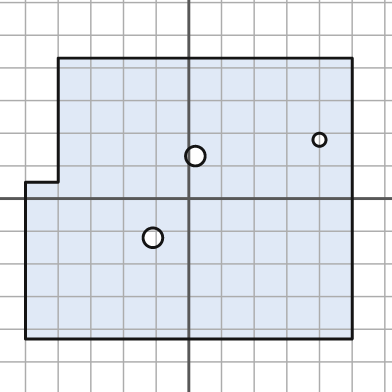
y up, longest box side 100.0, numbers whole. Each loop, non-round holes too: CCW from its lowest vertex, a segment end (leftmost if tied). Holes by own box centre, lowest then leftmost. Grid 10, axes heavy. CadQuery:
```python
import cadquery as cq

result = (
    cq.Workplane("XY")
    .moveTo(-50.0, -43.0)
    .lineTo(50.0, -43.0)
    .lineTo(50.0, 43.0)
    .lineTo(-40.0, 43.0)
    .lineTo(-40.0, 5.0)
    .lineTo(-50.0, 5.0)
    .close()
    .moveTo(-11.0, -12.0)
    .circle(3.0)
    .moveTo(2.0, 13.0)
    .circle(3.0)
    .moveTo(40.0, 18.0)
    .circle(2.0)
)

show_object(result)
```